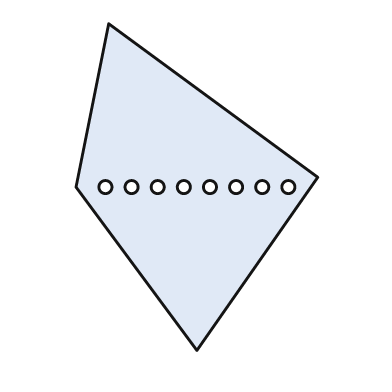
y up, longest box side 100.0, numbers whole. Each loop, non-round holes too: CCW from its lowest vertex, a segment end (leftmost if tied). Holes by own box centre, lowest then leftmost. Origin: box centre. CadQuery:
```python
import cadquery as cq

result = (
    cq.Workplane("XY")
    .moveTo(0.0, -50.0)
    .lineTo(37.0, 3.0)
    .lineTo(-27.0, 50.0)
    .lineTo(-37.0, 0.0)
    .close()
    .moveTo(-28.0, 0.0)
    .circle(2.0)
    .moveTo(-20.0, 0.0)
    .circle(2.0)
    .moveTo(-12.0, 0.0)
    .circle(2.0)
    .moveTo(-4.0, 0.0)
    .circle(2.0)
    .moveTo(4.0, 0.0)
    .circle(2.0)
    .moveTo(12.0, 0.0)
    .circle(2.0)
    .moveTo(20.0, 0.0)
    .circle(2.0)
    .moveTo(28.0, 0.0)
    .circle(2.0)
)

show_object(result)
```